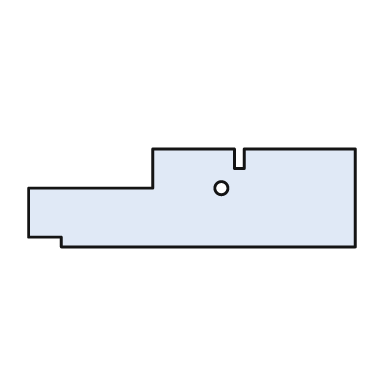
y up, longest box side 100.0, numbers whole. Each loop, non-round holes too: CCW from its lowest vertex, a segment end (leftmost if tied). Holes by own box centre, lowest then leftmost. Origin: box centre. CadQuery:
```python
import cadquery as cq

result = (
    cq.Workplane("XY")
    .moveTo(-40.0, -15.0)
    .lineTo(50.0, -15.0)
    .lineTo(50.0, 15.0)
    .lineTo(16.0, 15.0)
    .lineTo(16.0, 9.0)
    .lineTo(13.0, 9.0)
    .lineTo(13.0, 15.0)
    .lineTo(-12.0, 15.0)
    .lineTo(-12.0, 3.0)
    .lineTo(-50.0, 3.0)
    .lineTo(-50.0, -12.0)
    .lineTo(-40.0, -12.0)
    .close()
    .moveTo(9.0, 3.0)
    .circle(2.0)
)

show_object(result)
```